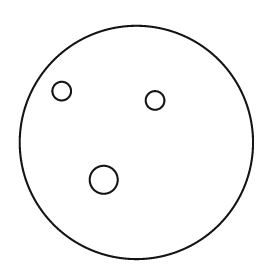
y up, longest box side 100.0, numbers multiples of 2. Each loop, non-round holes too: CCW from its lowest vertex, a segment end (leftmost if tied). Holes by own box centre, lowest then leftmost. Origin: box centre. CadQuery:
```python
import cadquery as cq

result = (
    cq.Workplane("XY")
    .moveTo(0.0, 0.0)
    .circle(50.0)
    .moveTo(-14.0, -16.0)
    .circle(6.0)
    .moveTo(8.0, 18.0)
    .circle(4.0)
    .moveTo(-32.0, 22.0)
    .circle(4.0)
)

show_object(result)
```